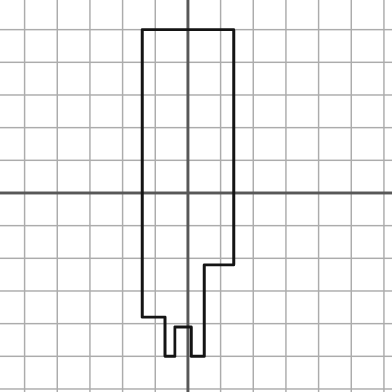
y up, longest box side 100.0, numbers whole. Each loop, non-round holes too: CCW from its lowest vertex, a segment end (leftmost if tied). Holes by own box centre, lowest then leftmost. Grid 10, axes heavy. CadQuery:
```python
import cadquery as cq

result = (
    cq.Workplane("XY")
    .moveTo(-7.0, -50.0)
    .lineTo(-4.0, -50.0)
    .lineTo(-4.0, -41.0)
    .lineTo(1.0, -41.0)
    .lineTo(1.0, -50.0)
    .lineTo(5.0, -50.0)
    .lineTo(5.0, -22.0)
    .lineTo(14.0, -22.0)
    .lineTo(14.0, 50.0)
    .lineTo(-14.0, 50.0)
    .lineTo(-14.0, -38.0)
    .lineTo(-7.0, -38.0)
    .close()
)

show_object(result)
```